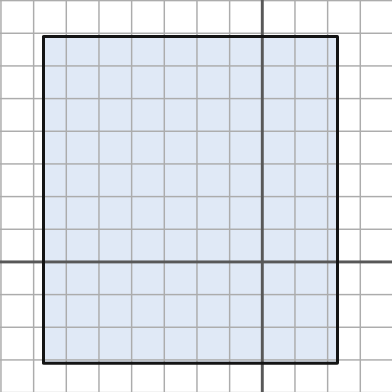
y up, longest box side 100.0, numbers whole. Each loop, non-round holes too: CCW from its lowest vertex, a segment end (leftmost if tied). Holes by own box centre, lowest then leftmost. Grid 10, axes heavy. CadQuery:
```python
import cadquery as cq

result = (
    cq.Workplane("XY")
    .moveTo(-67.0, -31.0)
    .lineTo(23.0, -31.0)
    .lineTo(23.0, 69.0)
    .lineTo(-67.0, 69.0)
    .close()
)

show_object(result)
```